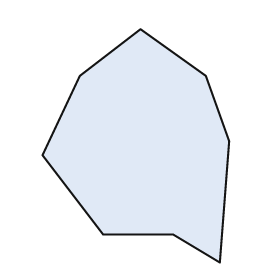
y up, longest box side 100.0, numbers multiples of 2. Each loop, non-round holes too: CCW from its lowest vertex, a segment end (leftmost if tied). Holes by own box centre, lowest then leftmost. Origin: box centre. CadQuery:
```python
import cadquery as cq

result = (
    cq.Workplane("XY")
    .moveTo(36.0, -50.0)
    .lineTo(40.0, 2.0)
    .lineTo(30.0, 30.0)
    .lineTo(2.0, 50.0)
    .lineTo(-24.0, 30.0)
    .lineTo(-40.0, -4.0)
    .lineTo(-14.0, -38.0)
    .lineTo(16.0, -38.0)
    .close()
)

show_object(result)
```